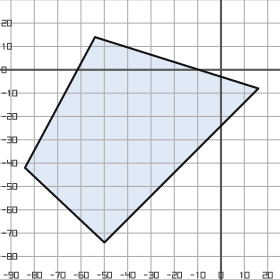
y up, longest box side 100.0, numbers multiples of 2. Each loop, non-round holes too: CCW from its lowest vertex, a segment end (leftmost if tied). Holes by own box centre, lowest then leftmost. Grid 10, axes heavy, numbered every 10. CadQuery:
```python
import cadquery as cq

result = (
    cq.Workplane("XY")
    .moveTo(-50.0, -74.0)
    .lineTo(16.0, -8.0)
    .lineTo(-54.0, 14.0)
    .lineTo(-84.0, -42.0)
    .close()
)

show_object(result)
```